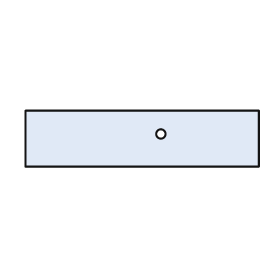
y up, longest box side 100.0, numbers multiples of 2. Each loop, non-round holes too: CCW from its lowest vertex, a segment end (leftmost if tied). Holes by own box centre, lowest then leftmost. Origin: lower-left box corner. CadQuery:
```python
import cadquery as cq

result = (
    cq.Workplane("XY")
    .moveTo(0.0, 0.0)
    .lineTo(100.0, 0.0)
    .lineTo(100.0, 24.0)
    .lineTo(0.0, 24.0)
    .close()
    .moveTo(58.0, 14.0)
    .circle(2.0)
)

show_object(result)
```